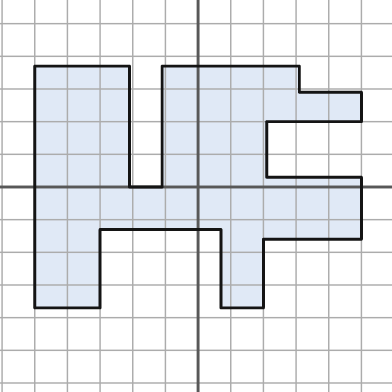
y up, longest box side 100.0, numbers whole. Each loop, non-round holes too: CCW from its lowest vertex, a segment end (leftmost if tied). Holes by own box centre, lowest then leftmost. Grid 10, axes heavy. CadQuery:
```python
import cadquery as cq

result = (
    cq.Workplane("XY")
    .moveTo(-50.0, -37.0)
    .lineTo(-30.0, -37.0)
    .lineTo(-30.0, -13.0)
    .lineTo(7.0, -13.0)
    .lineTo(7.0, -37.0)
    .lineTo(20.0, -37.0)
    .lineTo(20.0, -16.0)
    .lineTo(50.0, -16.0)
    .lineTo(50.0, 3.0)
    .lineTo(21.0, 3.0)
    .lineTo(21.0, 20.0)
    .lineTo(50.0, 20.0)
    .lineTo(50.0, 29.0)
    .lineTo(31.0, 29.0)
    .lineTo(31.0, 37.0)
    .lineTo(-11.0, 37.0)
    .lineTo(-11.0, 0.0)
    .lineTo(-21.0, 0.0)
    .lineTo(-21.0, 37.0)
    .lineTo(-50.0, 37.0)
    .close()
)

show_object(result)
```